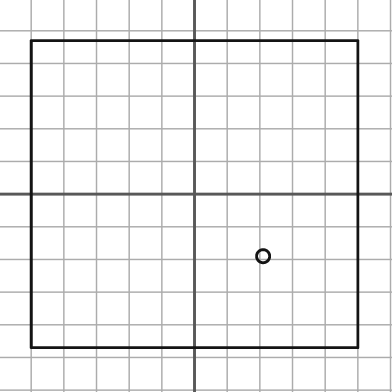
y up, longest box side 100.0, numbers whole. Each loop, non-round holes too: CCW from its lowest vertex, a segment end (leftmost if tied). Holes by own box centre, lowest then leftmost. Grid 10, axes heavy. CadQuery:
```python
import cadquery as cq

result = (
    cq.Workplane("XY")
    .moveTo(-50.0, -47.0)
    .lineTo(50.0, -47.0)
    .lineTo(50.0, 47.0)
    .lineTo(-50.0, 47.0)
    .close()
    .moveTo(21.0, -19.0)
    .circle(2.0)
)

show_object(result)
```